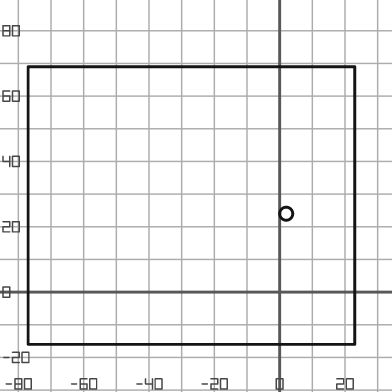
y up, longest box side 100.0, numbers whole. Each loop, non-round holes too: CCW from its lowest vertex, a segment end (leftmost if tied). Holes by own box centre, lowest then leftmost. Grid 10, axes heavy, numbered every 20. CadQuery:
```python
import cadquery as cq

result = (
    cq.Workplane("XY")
    .moveTo(-77.0, -16.0)
    .lineTo(23.0, -16.0)
    .lineTo(23.0, 69.0)
    .lineTo(-77.0, 69.0)
    .close()
    .moveTo(2.0, 24.0)
    .circle(2.0)
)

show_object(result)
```